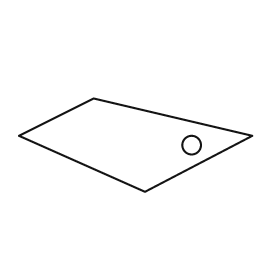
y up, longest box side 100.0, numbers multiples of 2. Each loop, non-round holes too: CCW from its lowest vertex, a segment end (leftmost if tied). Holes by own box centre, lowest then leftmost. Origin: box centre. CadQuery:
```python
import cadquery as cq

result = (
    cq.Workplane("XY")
    .moveTo(4.0, -20.0)
    .lineTo(50.0, 4.0)
    .lineTo(-18.0, 20.0)
    .lineTo(-50.0, 4.0)
    .close()
    .moveTo(24.0, 0.0)
    .circle(4.0)
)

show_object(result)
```